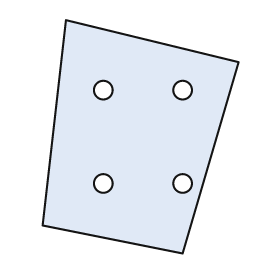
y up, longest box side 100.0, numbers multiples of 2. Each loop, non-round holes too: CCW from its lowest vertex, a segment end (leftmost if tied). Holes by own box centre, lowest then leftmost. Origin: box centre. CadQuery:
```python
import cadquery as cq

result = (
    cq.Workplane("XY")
    .moveTo(18.0, -50.0)
    .lineTo(42.0, 32.0)
    .lineTo(-32.0, 50.0)
    .lineTo(-42.0, -38.0)
    .close()
    .moveTo(-16.0, -20.0)
    .circle(4.0)
    .moveTo(18.0, -20.0)
    .circle(4.0)
    .moveTo(-16.0, 20.0)
    .circle(4.0)
    .moveTo(18.0, 20.0)
    .circle(4.0)
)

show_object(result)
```